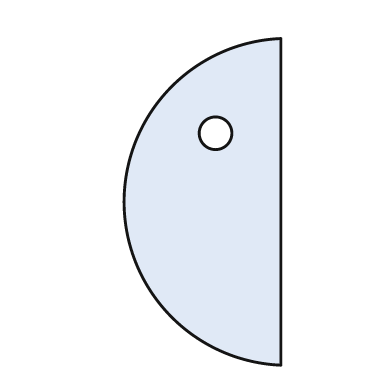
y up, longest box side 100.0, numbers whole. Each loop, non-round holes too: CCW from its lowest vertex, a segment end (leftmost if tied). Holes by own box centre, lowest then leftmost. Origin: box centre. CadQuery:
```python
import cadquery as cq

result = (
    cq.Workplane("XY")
    .moveTo(24.0, -50.0)
    .lineTo(24.0, 50.0)
    .threePointArc((-24.0, 0.0), (24.0, -50.0))
    .close()
    .moveTo(4.0, 21.0)
    .circle(5.0)
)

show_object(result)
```